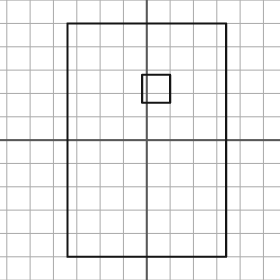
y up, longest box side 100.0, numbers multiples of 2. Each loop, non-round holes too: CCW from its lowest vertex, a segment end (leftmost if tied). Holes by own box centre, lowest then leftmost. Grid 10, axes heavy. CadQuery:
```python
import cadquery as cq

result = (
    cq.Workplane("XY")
    .moveTo(-34.0, -50.0)
    .lineTo(34.0, -50.0)
    .lineTo(34.0, 50.0)
    .lineTo(-34.0, 50.0)
    .close()
    .moveTo(-2.0, 16.0)
    .lineTo(10.0, 16.0)
    .lineTo(10.0, 28.0)
    .lineTo(-2.0, 28.0)
    .close()
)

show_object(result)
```